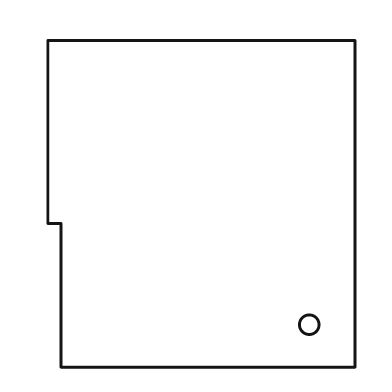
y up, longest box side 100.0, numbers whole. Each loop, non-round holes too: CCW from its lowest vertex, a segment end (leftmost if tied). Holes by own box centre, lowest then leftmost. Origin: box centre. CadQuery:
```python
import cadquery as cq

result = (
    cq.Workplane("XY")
    .moveTo(-43.0, -50.0)
    .lineTo(47.0, -50.0)
    .lineTo(47.0, 50.0)
    .lineTo(-47.0, 50.0)
    .lineTo(-47.0, -6.0)
    .lineTo(-43.0, -6.0)
    .close()
    .moveTo(33.0, -37.0)
    .circle(3.0)
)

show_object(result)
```